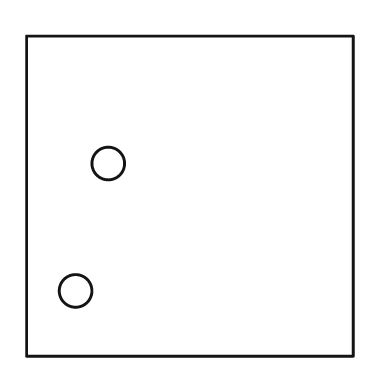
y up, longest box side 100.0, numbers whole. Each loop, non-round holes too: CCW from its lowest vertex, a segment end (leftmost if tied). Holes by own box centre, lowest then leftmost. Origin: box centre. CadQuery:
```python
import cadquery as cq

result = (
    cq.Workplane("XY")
    .moveTo(-50.0, -49.0)
    .lineTo(50.0, -49.0)
    .lineTo(50.0, 49.0)
    .lineTo(-50.0, 49.0)
    .close()
    .moveTo(-35.0, -29.0)
    .circle(5.0)
    .moveTo(-25.0, 10.0)
    .circle(5.0)
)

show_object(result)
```